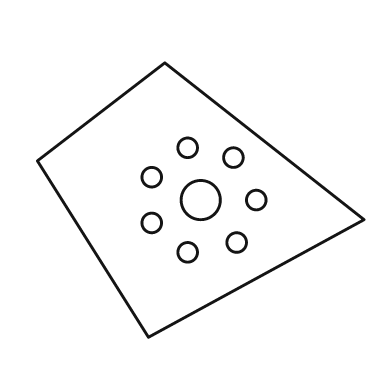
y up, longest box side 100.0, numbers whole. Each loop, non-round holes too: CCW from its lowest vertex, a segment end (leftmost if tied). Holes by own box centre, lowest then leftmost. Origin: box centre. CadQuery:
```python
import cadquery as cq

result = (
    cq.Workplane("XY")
    .moveTo(-16.0, -42.0)
    .lineTo(50.0, -6.0)
    .lineTo(-11.0, 42.0)
    .lineTo(-50.0, 12.0)
    .close()
    .moveTo(-4.0, -16.0)
    .circle(3.0)
    .moveTo(11.0, -13.0)
    .circle(3.0)
    .moveTo(-15.0, -7.0)
    .circle(3.0)
    .moveTo(0.0, 0.0)
    .circle(6.0)
    .moveTo(17.0, 0.0)
    .circle(3.0)
    .moveTo(-15.0, 7.0)
    .circle(3.0)
    .moveTo(10.0, 13.0)
    .circle(3.0)
    .moveTo(-4.0, 16.0)
    .circle(3.0)
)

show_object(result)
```